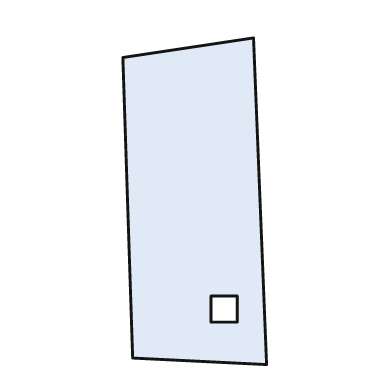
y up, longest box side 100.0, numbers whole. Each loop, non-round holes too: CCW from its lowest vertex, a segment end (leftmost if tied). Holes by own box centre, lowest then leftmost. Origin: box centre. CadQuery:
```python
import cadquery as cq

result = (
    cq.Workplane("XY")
    .moveTo(22.0, -50.0)
    .lineTo(18.0, 50.0)
    .lineTo(-22.0, 44.0)
    .lineTo(-19.0, -48.0)
    .close()
    .moveTo(5.0, -37.0)
    .lineTo(13.0, -37.0)
    .lineTo(13.0, -29.0)
    .lineTo(5.0, -29.0)
    .close()
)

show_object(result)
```